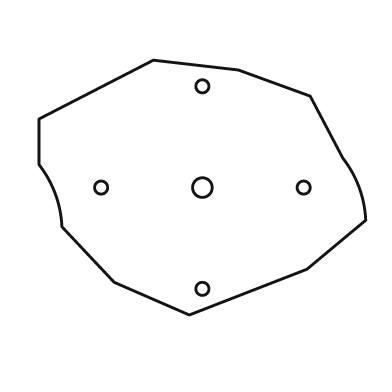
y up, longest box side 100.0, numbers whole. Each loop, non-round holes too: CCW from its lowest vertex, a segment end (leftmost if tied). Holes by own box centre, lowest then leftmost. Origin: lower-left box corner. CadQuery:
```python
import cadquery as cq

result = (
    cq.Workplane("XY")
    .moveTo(46.0, 0.0)
    .lineTo(82.0, 14.0)
    .lineTo(100.0, 29.0)
    .threePointArc((98.0, 39.0), (93.0, 48.0))
    .lineTo(83.0, 67.0)
    .lineTo(61.0, 75.0)
    .lineTo(35.0, 78.0)
    .lineTo(0.0, 60.0)
    .lineTo(0.0, 46.0)
    .threePointArc((5.0, 37.0), (7.0, 27.0))
    .lineTo(23.0, 10.0)
    .close()
    .moveTo(50.0, 8.0)
    .circle(2.0)
    .moveTo(19.0, 39.0)
    .circle(2.0)
    .moveTo(50.0, 39.0)
    .circle(3.0)
    .moveTo(81.0, 39.0)
    .circle(2.0)
    .moveTo(50.0, 70.0)
    .circle(2.0)
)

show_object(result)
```